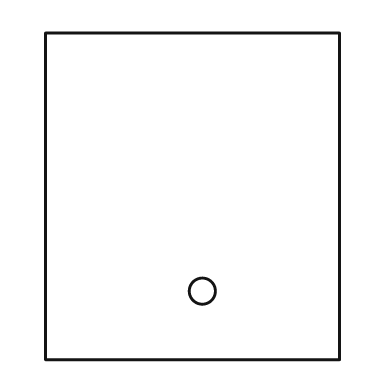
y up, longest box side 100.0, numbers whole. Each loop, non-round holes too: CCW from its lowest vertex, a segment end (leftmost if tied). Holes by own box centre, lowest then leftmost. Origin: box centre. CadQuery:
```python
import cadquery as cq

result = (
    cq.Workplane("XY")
    .moveTo(-45.0, -50.0)
    .lineTo(45.0, -50.0)
    .lineTo(45.0, 50.0)
    .lineTo(-45.0, 50.0)
    .close()
    .moveTo(3.0, -29.0)
    .circle(4.0)
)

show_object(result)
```